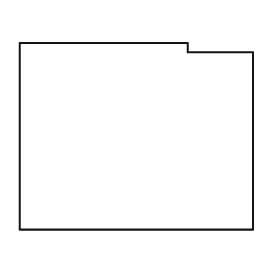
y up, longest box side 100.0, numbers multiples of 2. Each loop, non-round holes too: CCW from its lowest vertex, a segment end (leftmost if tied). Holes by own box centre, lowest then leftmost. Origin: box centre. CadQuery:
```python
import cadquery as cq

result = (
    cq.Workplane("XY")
    .moveTo(-50.0, -40.0)
    .lineTo(50.0, -40.0)
    .lineTo(50.0, 36.0)
    .lineTo(22.0, 36.0)
    .lineTo(22.0, 40.0)
    .lineTo(-50.0, 40.0)
    .close()
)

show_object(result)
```